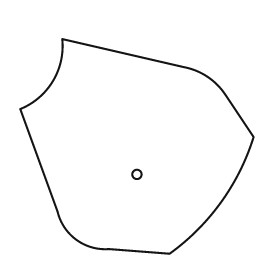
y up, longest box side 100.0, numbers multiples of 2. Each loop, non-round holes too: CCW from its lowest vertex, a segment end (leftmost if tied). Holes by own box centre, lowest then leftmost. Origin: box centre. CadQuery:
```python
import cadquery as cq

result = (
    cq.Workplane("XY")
    .moveTo(14.0, -46.0)
    .threePointArc((36.0, -24.0), (50.0, 4.0))
    .lineTo(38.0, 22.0)
    .threePointArc((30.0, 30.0), (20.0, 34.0))
    .lineTo(-32.0, 46.0)
    .threePointArc((-36.0, 28.0), (-50.0, 16.0))
    .lineTo(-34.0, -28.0)
    .threePointArc((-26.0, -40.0), (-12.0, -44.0))
    .close()
    .moveTo(0.0, -12.0)
    .circle(2.0)
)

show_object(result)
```